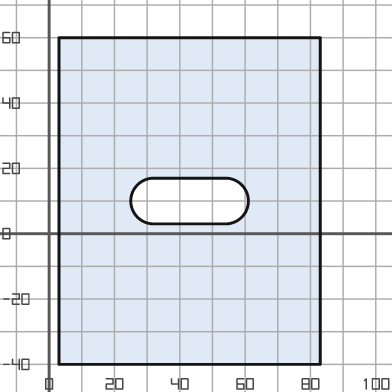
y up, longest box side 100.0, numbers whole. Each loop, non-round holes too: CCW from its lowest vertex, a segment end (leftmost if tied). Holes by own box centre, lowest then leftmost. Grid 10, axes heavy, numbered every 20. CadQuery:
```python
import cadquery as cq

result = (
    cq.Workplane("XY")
    .moveTo(3.0, -40.0)
    .lineTo(83.0, -40.0)
    .lineTo(83.0, 60.0)
    .lineTo(3.0, 60.0)
    .close()
    .moveTo(32.0, 3.0)
    .lineTo(54.0, 3.0)
    .threePointArc((61.0, 10.0), (54.0, 17.0))
    .lineTo(32.0, 17.0)
    .threePointArc((25.0, 10.0), (32.0, 3.0))
    .close()
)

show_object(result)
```